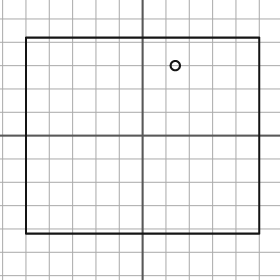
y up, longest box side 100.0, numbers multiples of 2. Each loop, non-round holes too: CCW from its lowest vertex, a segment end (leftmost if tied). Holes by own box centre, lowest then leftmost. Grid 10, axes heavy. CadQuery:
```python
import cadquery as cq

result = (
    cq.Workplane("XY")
    .moveTo(-50.0, -42.0)
    .lineTo(50.0, -42.0)
    .lineTo(50.0, 42.0)
    .lineTo(-50.0, 42.0)
    .close()
    .moveTo(14.0, 30.0)
    .circle(2.0)
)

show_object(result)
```